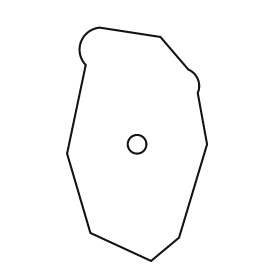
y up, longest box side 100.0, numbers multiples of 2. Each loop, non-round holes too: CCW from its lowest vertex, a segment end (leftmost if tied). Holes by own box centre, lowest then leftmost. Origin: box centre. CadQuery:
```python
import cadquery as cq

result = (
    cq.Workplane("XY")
    .moveTo(6.0, -50.0)
    .lineTo(18.0, -40.0)
    .lineTo(30.0, 0.0)
    .lineTo(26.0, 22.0)
    .threePointArc((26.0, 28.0), (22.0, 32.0))
    .lineTo(10.0, 46.0)
    .lineTo(-16.0, 50.0)
    .threePointArc((-24.0, 44.0), (-22.0, 34.0))
    .lineTo(-30.0, -4.0)
    .lineTo(-20.0, -38.0)
    .close()
    .moveTo(0.0, 0.0)
    .circle(4.0)
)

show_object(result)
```